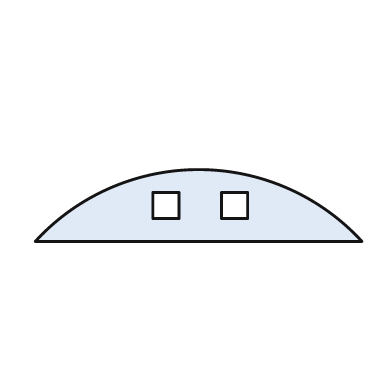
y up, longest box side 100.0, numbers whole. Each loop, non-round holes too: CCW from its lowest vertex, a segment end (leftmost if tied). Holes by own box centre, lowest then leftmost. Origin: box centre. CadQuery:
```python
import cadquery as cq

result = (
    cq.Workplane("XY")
    .moveTo(-50.0, -11.0)
    .lineTo(50.0, -11.0)
    .threePointArc((0.0, 11.0), (-50.0, -11.0))
    .close()
    .moveTo(-14.0, -4.0)
    .lineTo(-6.0, -4.0)
    .lineTo(-6.0, 4.0)
    .lineTo(-14.0, 4.0)
    .close()
    .moveTo(7.0, -4.0)
    .lineTo(15.0, -4.0)
    .lineTo(15.0, 4.0)
    .lineTo(7.0, 4.0)
    .close()
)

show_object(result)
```